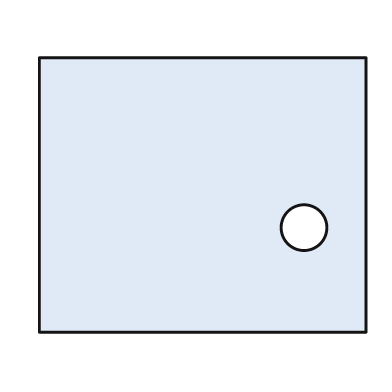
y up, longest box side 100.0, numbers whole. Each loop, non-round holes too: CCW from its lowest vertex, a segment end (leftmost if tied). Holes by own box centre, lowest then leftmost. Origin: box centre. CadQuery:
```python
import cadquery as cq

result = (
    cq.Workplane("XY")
    .moveTo(-50.0, -42.0)
    .lineTo(50.0, -42.0)
    .lineTo(50.0, 42.0)
    .lineTo(-50.0, 42.0)
    .close()
    .moveTo(31.0, -10.0)
    .circle(7.0)
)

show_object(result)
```